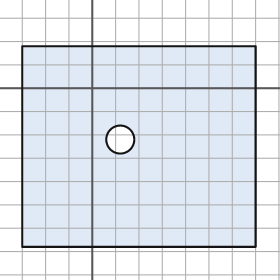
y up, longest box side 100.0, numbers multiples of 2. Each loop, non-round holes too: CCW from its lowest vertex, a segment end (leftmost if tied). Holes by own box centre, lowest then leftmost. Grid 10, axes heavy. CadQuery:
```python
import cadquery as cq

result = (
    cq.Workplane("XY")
    .moveTo(-30.0, -68.0)
    .lineTo(70.0, -68.0)
    .lineTo(70.0, 18.0)
    .lineTo(-30.0, 18.0)
    .close()
    .moveTo(12.0, -22.0)
    .circle(6.0)
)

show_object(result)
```